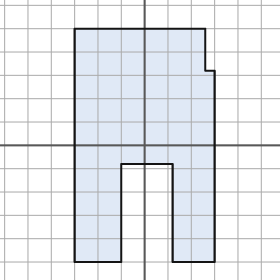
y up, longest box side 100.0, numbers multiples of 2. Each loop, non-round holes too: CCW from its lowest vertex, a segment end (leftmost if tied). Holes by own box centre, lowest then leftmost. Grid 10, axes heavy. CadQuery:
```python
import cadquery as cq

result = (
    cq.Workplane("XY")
    .moveTo(-30.0, -50.0)
    .lineTo(-10.0, -50.0)
    .lineTo(-10.0, -8.0)
    .lineTo(12.0, -8.0)
    .lineTo(12.0, -50.0)
    .lineTo(30.0, -50.0)
    .lineTo(30.0, 32.0)
    .lineTo(26.0, 32.0)
    .lineTo(26.0, 50.0)
    .lineTo(-30.0, 50.0)
    .close()
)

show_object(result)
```